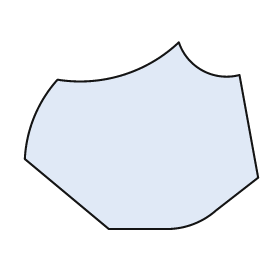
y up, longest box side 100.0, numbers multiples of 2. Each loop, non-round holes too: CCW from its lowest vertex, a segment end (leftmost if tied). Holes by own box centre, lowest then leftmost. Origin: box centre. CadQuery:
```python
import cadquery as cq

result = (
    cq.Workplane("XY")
    .moveTo(-14.0, -40.0)
    .lineTo(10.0, -40.0)
    .threePointArc((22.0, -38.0), (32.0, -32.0))
    .lineTo(50.0, -18.0)
    .lineTo(42.0, 26.0)
    .threePointArc((26.0, 28.0), (16.0, 40.0))
    .threePointArc((-8.0, 26.0), (-36.0, 24.0))
    .threePointArc((-46.0, 8.0), (-50.0, -10.0))
    .close()
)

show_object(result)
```